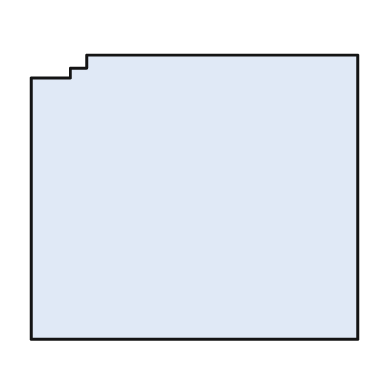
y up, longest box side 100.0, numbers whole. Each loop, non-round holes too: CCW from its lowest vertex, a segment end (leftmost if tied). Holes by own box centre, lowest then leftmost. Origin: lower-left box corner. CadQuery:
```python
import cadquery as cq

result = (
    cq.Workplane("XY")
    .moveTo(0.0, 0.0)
    .lineTo(100.0, 0.0)
    .lineTo(100.0, 87.0)
    .lineTo(17.0, 87.0)
    .lineTo(17.0, 83.0)
    .lineTo(12.0, 83.0)
    .lineTo(12.0, 80.0)
    .lineTo(0.0, 80.0)
    .close()
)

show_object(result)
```